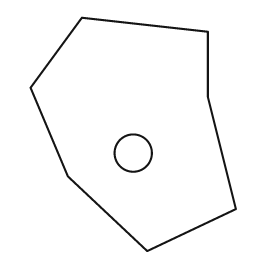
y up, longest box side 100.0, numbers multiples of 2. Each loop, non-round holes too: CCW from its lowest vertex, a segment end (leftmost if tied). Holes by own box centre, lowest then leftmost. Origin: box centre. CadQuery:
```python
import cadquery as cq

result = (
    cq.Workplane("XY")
    .moveTo(6.0, -50.0)
    .lineTo(44.0, -32.0)
    .lineTo(32.0, 16.0)
    .lineTo(32.0, 44.0)
    .lineTo(-22.0, 50.0)
    .lineTo(-44.0, 20.0)
    .lineTo(-28.0, -18.0)
    .close()
    .moveTo(0.0, -8.0)
    .circle(8.0)
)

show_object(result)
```